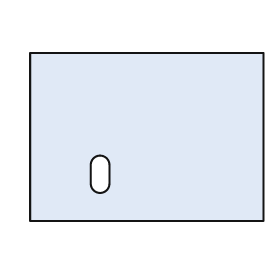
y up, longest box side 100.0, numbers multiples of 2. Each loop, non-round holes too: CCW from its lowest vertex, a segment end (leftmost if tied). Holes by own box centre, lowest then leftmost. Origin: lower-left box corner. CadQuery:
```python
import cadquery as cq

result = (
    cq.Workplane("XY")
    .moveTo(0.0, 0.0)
    .lineTo(100.0, 0.0)
    .lineTo(100.0, 72.0)
    .lineTo(0.0, 72.0)
    .close()
    .moveTo(26.0, 16.0)
    .threePointArc((30.0, 12.0), (34.0, 16.0))
    .lineTo(34.0, 24.0)
    .threePointArc((30.0, 28.0), (26.0, 24.0))
    .close()
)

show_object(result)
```